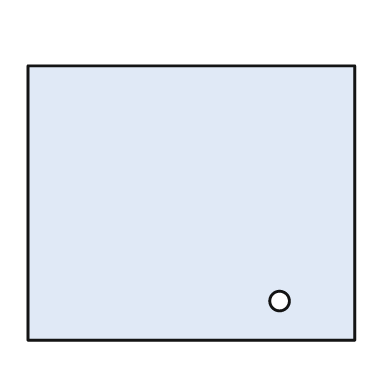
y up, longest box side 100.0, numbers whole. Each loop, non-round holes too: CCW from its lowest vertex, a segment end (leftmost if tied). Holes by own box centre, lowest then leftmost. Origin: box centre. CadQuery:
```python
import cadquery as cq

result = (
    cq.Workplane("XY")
    .moveTo(-50.0, -42.0)
    .lineTo(50.0, -42.0)
    .lineTo(50.0, 42.0)
    .lineTo(-50.0, 42.0)
    .close()
    .moveTo(27.0, -30.0)
    .circle(3.0)
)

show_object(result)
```